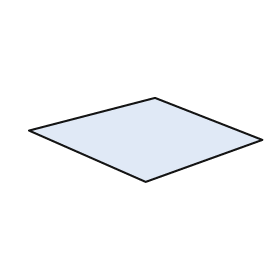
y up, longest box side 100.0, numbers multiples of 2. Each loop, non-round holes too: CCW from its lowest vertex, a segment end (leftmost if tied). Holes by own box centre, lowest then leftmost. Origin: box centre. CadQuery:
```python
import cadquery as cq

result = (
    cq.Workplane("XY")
    .moveTo(0.0, -18.0)
    .lineTo(50.0, 0.0)
    .lineTo(4.0, 18.0)
    .lineTo(-50.0, 4.0)
    .close()
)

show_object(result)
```